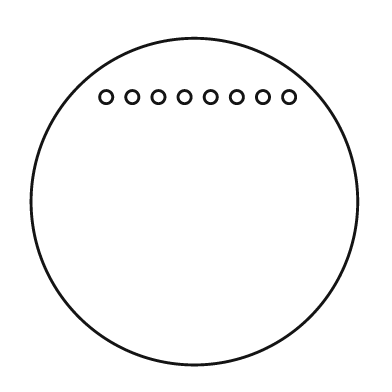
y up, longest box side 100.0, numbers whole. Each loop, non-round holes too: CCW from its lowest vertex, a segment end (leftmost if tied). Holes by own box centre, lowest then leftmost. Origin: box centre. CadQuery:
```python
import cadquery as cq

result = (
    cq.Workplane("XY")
    .moveTo(0.0, 0.0)
    .circle(50.0)
    .moveTo(-27.0, 32.0)
    .circle(2.0)
    .moveTo(-19.0, 32.0)
    .circle(2.0)
    .moveTo(-11.0, 32.0)
    .circle(2.0)
    .moveTo(-3.0, 32.0)
    .circle(2.0)
    .moveTo(5.0, 32.0)
    .circle(2.0)
    .moveTo(13.0, 32.0)
    .circle(2.0)
    .moveTo(21.0, 32.0)
    .circle(2.0)
    .moveTo(29.0, 32.0)
    .circle(2.0)
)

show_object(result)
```